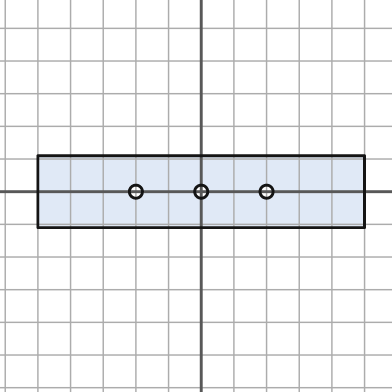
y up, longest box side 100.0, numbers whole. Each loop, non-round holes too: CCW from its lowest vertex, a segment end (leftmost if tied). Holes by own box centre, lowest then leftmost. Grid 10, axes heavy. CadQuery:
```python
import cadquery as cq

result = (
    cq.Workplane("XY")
    .moveTo(-50.0, -11.0)
    .lineTo(50.0, -11.0)
    .lineTo(50.0, 11.0)
    .lineTo(-50.0, 11.0)
    .close()
    .moveTo(-20.0, 0.0)
    .circle(2.0)
    .moveTo(0.0, 0.0)
    .circle(2.0)
    .moveTo(20.0, 0.0)
    .circle(2.0)
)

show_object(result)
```